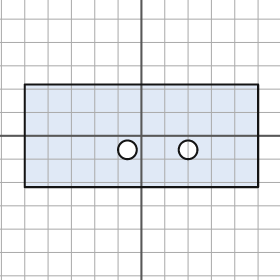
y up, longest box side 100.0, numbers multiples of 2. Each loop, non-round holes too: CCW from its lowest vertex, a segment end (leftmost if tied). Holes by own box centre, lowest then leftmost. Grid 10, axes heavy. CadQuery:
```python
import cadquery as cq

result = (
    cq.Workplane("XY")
    .moveTo(-50.0, -22.0)
    .lineTo(50.0, -22.0)
    .lineTo(50.0, 22.0)
    .lineTo(-50.0, 22.0)
    .close()
    .moveTo(-6.0, -6.0)
    .circle(4.0)
    .moveTo(20.0, -6.0)
    .circle(4.0)
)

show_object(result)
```